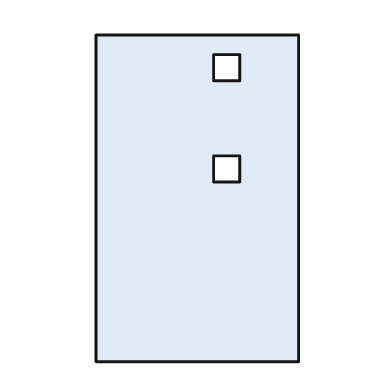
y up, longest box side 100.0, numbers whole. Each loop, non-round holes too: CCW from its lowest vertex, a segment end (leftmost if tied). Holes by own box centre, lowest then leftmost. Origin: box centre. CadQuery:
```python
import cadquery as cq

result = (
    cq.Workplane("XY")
    .moveTo(-31.0, -50.0)
    .lineTo(31.0, -50.0)
    .lineTo(31.0, 50.0)
    .lineTo(-31.0, 50.0)
    .close()
    .moveTo(5.0, 5.0)
    .lineTo(13.0, 5.0)
    .lineTo(13.0, 13.0)
    .lineTo(5.0, 13.0)
    .close()
    .moveTo(5.0, 36.0)
    .lineTo(13.0, 36.0)
    .lineTo(13.0, 44.0)
    .lineTo(5.0, 44.0)
    .close()
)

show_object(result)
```